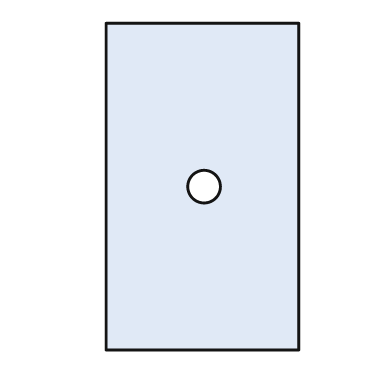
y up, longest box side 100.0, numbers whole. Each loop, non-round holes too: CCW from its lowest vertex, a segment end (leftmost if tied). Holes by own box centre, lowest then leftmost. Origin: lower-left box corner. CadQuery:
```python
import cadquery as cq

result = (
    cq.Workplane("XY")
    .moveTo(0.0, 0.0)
    .lineTo(59.0, 0.0)
    .lineTo(59.0, 100.0)
    .lineTo(0.0, 100.0)
    .close()
    .moveTo(30.0, 50.0)
    .circle(5.0)
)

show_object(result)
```